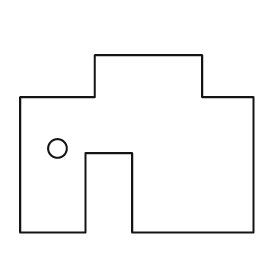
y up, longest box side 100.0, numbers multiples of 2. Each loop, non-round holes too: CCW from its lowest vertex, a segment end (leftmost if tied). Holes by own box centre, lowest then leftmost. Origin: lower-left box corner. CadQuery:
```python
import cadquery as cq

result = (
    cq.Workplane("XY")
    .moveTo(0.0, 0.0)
    .lineTo(28.0, 0.0)
    .lineTo(28.0, 34.0)
    .lineTo(48.0, 34.0)
    .lineTo(48.0, 0.0)
    .lineTo(100.0, 0.0)
    .lineTo(100.0, 58.0)
    .lineTo(78.0, 58.0)
    .lineTo(78.0, 76.0)
    .lineTo(32.0, 76.0)
    .lineTo(32.0, 58.0)
    .lineTo(0.0, 58.0)
    .close()
    .moveTo(16.0, 36.0)
    .circle(4.0)
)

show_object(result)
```